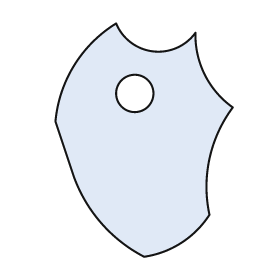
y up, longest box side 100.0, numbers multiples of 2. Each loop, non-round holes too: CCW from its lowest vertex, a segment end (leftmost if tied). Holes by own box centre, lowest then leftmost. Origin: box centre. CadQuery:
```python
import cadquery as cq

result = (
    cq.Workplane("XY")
    .moveTo(0.0, -50.0)
    .threePointArc((16.0, -44.0), (28.0, -32.0))
    .threePointArc((28.0, -8.0), (38.0, 14.0))
    .threePointArc((26.0, 28.0), (22.0, 46.0))
    .threePointArc((4.0, 38.0), (-12.0, 50.0))
    .threePointArc((-30.0, 32.0), (-38.0, 8.0))
    .lineTo(-30.0, -16.0)
    .threePointArc((-18.0, -36.0), (0.0, -50.0))
    .close()
    .moveTo(-4.0, 20.0)
    .circle(8.0)
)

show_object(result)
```